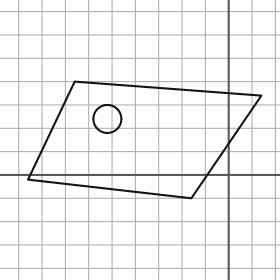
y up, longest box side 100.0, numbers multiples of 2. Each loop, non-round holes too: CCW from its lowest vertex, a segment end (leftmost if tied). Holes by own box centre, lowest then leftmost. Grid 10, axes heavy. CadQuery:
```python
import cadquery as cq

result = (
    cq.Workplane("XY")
    .moveTo(-16.0, -10.0)
    .lineTo(14.0, 34.0)
    .lineTo(-66.0, 40.0)
    .lineTo(-86.0, -2.0)
    .close()
    .moveTo(-52.0, 24.0)
    .circle(6.0)
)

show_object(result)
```